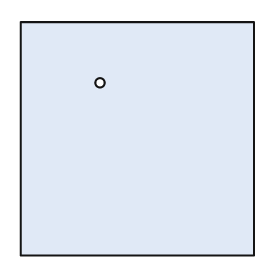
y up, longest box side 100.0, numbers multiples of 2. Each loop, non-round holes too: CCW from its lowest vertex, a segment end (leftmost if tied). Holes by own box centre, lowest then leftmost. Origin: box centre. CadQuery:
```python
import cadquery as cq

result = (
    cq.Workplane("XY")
    .moveTo(-50.0, -50.0)
    .lineTo(50.0, -50.0)
    .lineTo(50.0, 50.0)
    .lineTo(-50.0, 50.0)
    .close()
    .moveTo(-16.0, 24.0)
    .circle(2.0)
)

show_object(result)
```